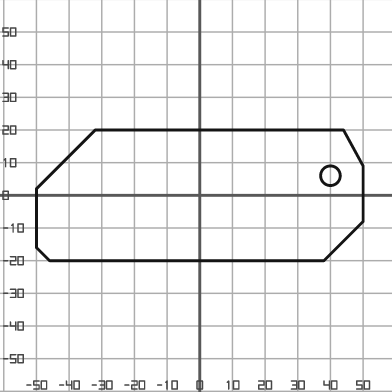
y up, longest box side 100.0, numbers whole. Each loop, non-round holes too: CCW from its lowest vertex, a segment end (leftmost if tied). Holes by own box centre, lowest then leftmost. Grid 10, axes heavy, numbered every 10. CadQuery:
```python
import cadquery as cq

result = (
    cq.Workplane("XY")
    .moveTo(-46.0, -20.0)
    .lineTo(38.0, -20.0)
    .lineTo(50.0, -8.0)
    .lineTo(50.0, 9.0)
    .lineTo(44.0, 20.0)
    .lineTo(-32.0, 20.0)
    .lineTo(-50.0, 2.0)
    .lineTo(-50.0, -16.0)
    .close()
    .moveTo(40.0, 6.0)
    .circle(3.0)
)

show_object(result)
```